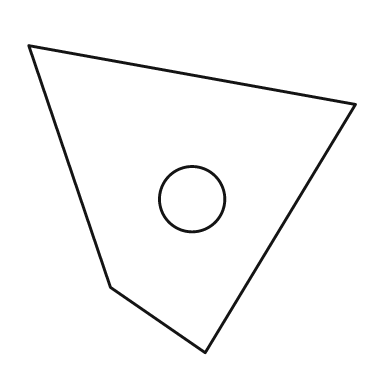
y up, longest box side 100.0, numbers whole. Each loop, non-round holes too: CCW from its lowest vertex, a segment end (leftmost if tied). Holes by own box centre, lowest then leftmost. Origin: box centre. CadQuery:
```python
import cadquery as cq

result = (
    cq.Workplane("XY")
    .moveTo(4.0, -47.0)
    .lineTo(50.0, 29.0)
    .lineTo(-50.0, 47.0)
    .lineTo(-25.0, -27.0)
    .close()
    .moveTo(0.0, 0.0)
    .circle(10.0)
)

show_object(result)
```